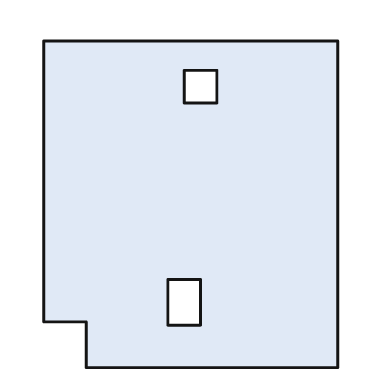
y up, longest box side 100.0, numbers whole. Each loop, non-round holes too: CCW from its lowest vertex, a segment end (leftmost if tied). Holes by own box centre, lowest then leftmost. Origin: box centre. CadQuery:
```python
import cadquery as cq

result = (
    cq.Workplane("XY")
    .moveTo(-32.0, -50.0)
    .lineTo(45.0, -50.0)
    .lineTo(45.0, 50.0)
    .lineTo(-45.0, 50.0)
    .lineTo(-45.0, -36.0)
    .lineTo(-32.0, -36.0)
    .close()
    .moveTo(-7.0, -37.0)
    .lineTo(3.0, -37.0)
    .lineTo(3.0, -23.0)
    .lineTo(-7.0, -23.0)
    .close()
    .moveTo(-2.0, 31.0)
    .lineTo(8.0, 31.0)
    .lineTo(8.0, 41.0)
    .lineTo(-2.0, 41.0)
    .close()
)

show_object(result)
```